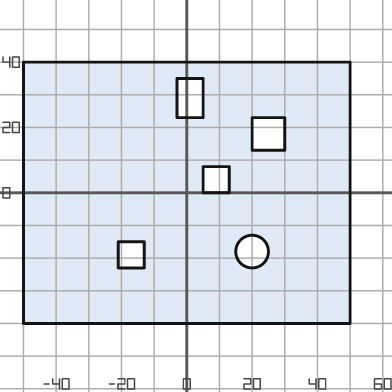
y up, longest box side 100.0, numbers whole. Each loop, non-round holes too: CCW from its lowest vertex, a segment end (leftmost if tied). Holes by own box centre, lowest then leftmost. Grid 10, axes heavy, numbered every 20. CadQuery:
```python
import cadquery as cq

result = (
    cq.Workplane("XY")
    .moveTo(-50.0, -40.0)
    .lineTo(50.0, -40.0)
    .lineTo(50.0, 40.0)
    .lineTo(-50.0, 40.0)
    .close()
    .moveTo(-21.0, -23.0)
    .lineTo(-13.0, -23.0)
    .lineTo(-13.0, -15.0)
    .lineTo(-21.0, -15.0)
    .close()
    .moveTo(20.0, -18.0)
    .circle(5.0)
    .moveTo(5.0, 0.0)
    .lineTo(13.0, 0.0)
    .lineTo(13.0, 8.0)
    .lineTo(5.0, 8.0)
    .close()
    .moveTo(20.0, 13.0)
    .lineTo(30.0, 13.0)
    .lineTo(30.0, 23.0)
    .lineTo(20.0, 23.0)
    .close()
    .moveTo(-3.0, 23.0)
    .lineTo(5.0, 23.0)
    .lineTo(5.0, 35.0)
    .lineTo(-3.0, 35.0)
    .close()
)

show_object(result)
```